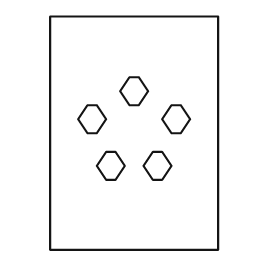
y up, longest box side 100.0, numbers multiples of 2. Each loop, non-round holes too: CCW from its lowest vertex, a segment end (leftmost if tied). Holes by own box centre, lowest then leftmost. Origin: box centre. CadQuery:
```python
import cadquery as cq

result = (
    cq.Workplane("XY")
    .moveTo(-36.0, -50.0)
    .lineTo(36.0, -50.0)
    .lineTo(36.0, 50.0)
    .lineTo(-36.0, 50.0)
    .close()
    .moveTo(-12.0, -20.0)
    .lineTo(-8.0, -20.0)
    .lineTo(-4.0, -14.0)
    .lineTo(-8.0, -8.0)
    .lineTo(-12.0, -8.0)
    .lineTo(-16.0, -14.0)
    .close()
    .moveTo(8.0, -20.0)
    .lineTo(12.0, -20.0)
    .lineTo(16.0, -14.0)
    .lineTo(12.0, -8.0)
    .lineTo(8.0, -8.0)
    .lineTo(4.0, -14.0)
    .close()
    .moveTo(-20.0, 0.0)
    .lineTo(-16.0, 0.0)
    .lineTo(-12.0, 6.0)
    .lineTo(-16.0, 12.0)
    .lineTo(-20.0, 12.0)
    .lineTo(-24.0, 6.0)
    .close()
    .moveTo(16.0, 0.0)
    .lineTo(20.0, 0.0)
    .lineTo(24.0, 6.0)
    .lineTo(20.0, 12.0)
    .lineTo(16.0, 12.0)
    .lineTo(12.0, 6.0)
    .close()
    .moveTo(-2.0, 12.0)
    .lineTo(2.0, 12.0)
    .lineTo(6.0, 18.0)
    .lineTo(2.0, 24.0)
    .lineTo(-2.0, 24.0)
    .lineTo(-6.0, 18.0)
    .close()
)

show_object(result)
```